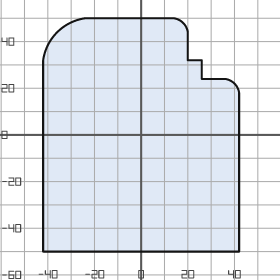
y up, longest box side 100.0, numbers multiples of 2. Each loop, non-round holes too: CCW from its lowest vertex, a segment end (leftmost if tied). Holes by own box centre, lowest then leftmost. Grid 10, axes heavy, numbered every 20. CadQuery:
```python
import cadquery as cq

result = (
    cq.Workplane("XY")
    .moveTo(-42.0, -50.0)
    .lineTo(42.0, -50.0)
    .lineTo(42.0, 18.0)
    .threePointArc((40.0, 22.0), (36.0, 24.0))
    .lineTo(26.0, 24.0)
    .lineTo(26.0, 32.0)
    .lineTo(20.0, 32.0)
    .lineTo(20.0, 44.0)
    .threePointArc((18.0, 48.0), (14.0, 50.0))
    .lineTo(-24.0, 50.0)
    .threePointArc((-36.0, 44.0), (-42.0, 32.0))
    .close()
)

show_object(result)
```